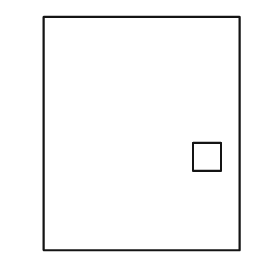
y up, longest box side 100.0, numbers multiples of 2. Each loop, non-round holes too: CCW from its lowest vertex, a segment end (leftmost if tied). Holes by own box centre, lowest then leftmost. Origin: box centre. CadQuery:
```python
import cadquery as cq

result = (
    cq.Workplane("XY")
    .moveTo(-42.0, -50.0)
    .lineTo(42.0, -50.0)
    .lineTo(42.0, 50.0)
    .lineTo(-42.0, 50.0)
    .close()
    .moveTo(22.0, -16.0)
    .lineTo(34.0, -16.0)
    .lineTo(34.0, -4.0)
    .lineTo(22.0, -4.0)
    .close()
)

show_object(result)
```